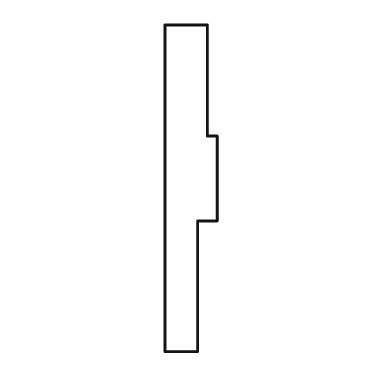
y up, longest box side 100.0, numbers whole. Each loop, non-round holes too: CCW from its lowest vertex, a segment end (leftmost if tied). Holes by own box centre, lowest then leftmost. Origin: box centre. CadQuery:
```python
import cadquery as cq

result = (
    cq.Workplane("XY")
    .moveTo(-8.0, -50.0)
    .lineTo(2.0, -50.0)
    .lineTo(2.0, -10.0)
    .lineTo(8.0, -10.0)
    .lineTo(8.0, 16.0)
    .lineTo(5.0, 16.0)
    .lineTo(5.0, 50.0)
    .lineTo(-8.0, 50.0)
    .close()
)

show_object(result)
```